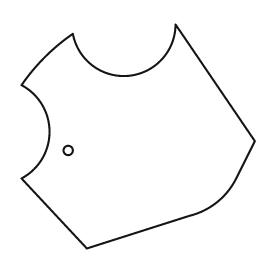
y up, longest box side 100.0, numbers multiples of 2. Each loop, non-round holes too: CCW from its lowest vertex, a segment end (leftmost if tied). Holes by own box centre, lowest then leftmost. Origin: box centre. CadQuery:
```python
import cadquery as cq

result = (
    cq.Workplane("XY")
    .moveTo(-22.0, -48.0)
    .lineTo(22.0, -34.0)
    .threePointArc((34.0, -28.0), (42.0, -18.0))
    .lineTo(50.0, -2.0)
    .lineTo(16.0, 48.0)
    .threePointArc((-4.0, 26.0), (-28.0, 44.0))
    .threePointArc((-40.0, 34.0), (-50.0, 22.0))
    .threePointArc((-38.0, 2.0), (-50.0, -18.0))
    .close()
    .moveTo(-30.0, -6.0)
    .circle(2.0)
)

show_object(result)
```